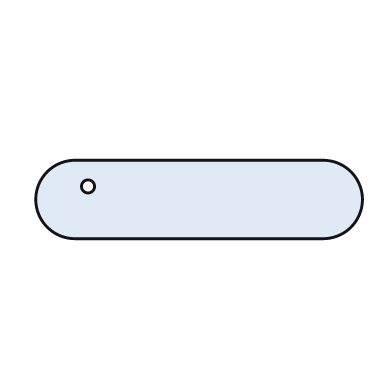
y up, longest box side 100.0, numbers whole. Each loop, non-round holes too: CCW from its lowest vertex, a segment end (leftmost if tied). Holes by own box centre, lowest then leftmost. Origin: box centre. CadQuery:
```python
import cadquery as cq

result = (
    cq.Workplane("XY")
    .moveTo(-38.0, -12.0)
    .lineTo(38.0, -12.0)
    .threePointArc((50.0, 0.0), (38.0, 12.0))
    .lineTo(-38.0, 12.0)
    .threePointArc((-50.0, 0.0), (-38.0, -12.0))
    .close()
    .moveTo(-34.0, 4.0)
    .circle(2.0)
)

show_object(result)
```